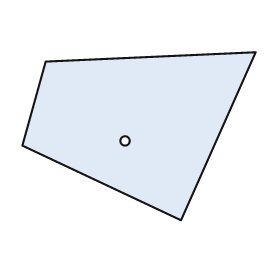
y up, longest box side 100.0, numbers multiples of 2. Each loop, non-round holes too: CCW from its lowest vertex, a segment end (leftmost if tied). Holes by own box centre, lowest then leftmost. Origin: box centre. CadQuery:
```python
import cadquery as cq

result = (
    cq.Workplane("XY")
    .moveTo(18.0, -36.0)
    .lineTo(50.0, 36.0)
    .lineTo(-40.0, 32.0)
    .lineTo(-50.0, -4.0)
    .close()
    .moveTo(-6.0, -2.0)
    .circle(2.0)
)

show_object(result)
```